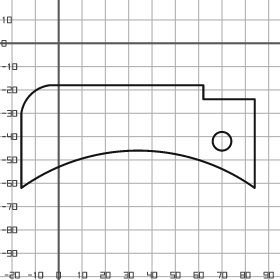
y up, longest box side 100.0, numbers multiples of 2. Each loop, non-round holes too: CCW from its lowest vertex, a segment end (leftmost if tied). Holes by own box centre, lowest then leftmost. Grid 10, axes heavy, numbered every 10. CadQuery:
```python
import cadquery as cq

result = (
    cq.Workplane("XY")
    .moveTo(-16.0, -62.0)
    .threePointArc((34.0, -46.0), (84.0, -62.0))
    .lineTo(84.0, -24.0)
    .lineTo(62.0, -24.0)
    .lineTo(62.0, -18.0)
    .lineTo(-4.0, -18.0)
    .threePointArc((-12.0, -22.0), (-16.0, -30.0))
    .close()
    .moveTo(70.0, -42.0)
    .circle(4.0)
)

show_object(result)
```